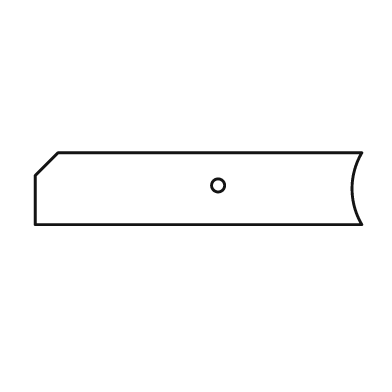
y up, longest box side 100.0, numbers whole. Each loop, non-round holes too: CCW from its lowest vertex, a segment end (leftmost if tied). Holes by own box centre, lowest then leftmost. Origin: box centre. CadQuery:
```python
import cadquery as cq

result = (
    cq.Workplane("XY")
    .moveTo(-50.0, -11.0)
    .lineTo(50.0, -11.0)
    .threePointArc((47.0, 0.0), (50.0, 11.0))
    .lineTo(-43.0, 11.0)
    .lineTo(-50.0, 4.0)
    .close()
    .moveTo(6.0, 1.0)
    .circle(2.0)
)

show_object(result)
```